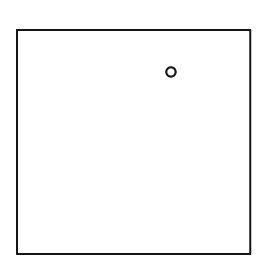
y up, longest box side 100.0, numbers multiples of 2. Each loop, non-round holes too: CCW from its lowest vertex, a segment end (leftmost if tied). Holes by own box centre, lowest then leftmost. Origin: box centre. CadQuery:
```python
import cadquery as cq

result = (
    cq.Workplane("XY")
    .moveTo(-50.0, -48.0)
    .lineTo(50.0, -48.0)
    .lineTo(50.0, 48.0)
    .lineTo(-50.0, 48.0)
    .close()
    .moveTo(16.0, 30.0)
    .circle(2.0)
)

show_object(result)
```